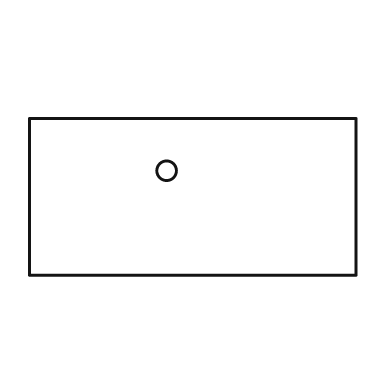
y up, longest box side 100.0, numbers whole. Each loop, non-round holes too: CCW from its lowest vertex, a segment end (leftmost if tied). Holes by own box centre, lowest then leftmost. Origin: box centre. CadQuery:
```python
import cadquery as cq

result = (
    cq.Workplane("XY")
    .moveTo(-50.0, -24.0)
    .lineTo(50.0, -24.0)
    .lineTo(50.0, 24.0)
    .lineTo(-50.0, 24.0)
    .close()
    .moveTo(-8.0, 8.0)
    .circle(3.0)
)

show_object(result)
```